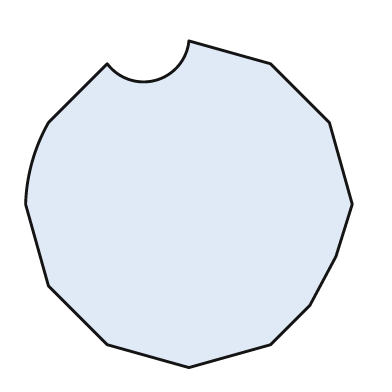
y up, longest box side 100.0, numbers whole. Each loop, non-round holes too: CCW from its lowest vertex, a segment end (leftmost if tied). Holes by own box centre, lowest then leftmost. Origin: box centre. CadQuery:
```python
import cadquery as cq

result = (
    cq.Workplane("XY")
    .moveTo(0.0, -50.0)
    .lineTo(25.0, -43.0)
    .lineTo(37.0, -31.0)
    .lineTo(45.0, -16.0)
    .lineTo(50.0, 0.0)
    .lineTo(43.0, 25.0)
    .lineTo(25.0, 43.0)
    .lineTo(0.0, 50.0)
    .threePointArc((-10.0, 38.0), (-25.0, 43.0))
    .lineTo(-43.0, 25.0)
    .threePointArc((-48.0, 13.0), (-50.0, 0.0))
    .lineTo(-43.0, -25.0)
    .lineTo(-25.0, -43.0)
    .close()
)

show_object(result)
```